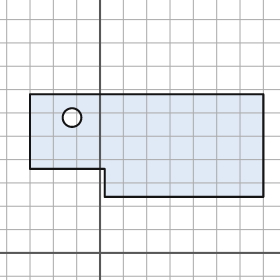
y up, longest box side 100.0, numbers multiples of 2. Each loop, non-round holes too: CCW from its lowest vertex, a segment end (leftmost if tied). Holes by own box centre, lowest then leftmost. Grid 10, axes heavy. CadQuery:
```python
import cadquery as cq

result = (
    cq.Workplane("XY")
    .moveTo(2.0, 24.0)
    .lineTo(70.0, 24.0)
    .lineTo(70.0, 68.0)
    .lineTo(-30.0, 68.0)
    .lineTo(-30.0, 36.0)
    .lineTo(2.0, 36.0)
    .close()
    .moveTo(-12.0, 58.0)
    .circle(4.0)
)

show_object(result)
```